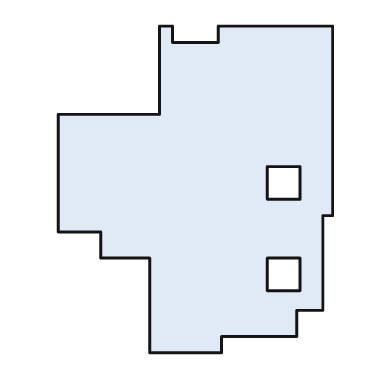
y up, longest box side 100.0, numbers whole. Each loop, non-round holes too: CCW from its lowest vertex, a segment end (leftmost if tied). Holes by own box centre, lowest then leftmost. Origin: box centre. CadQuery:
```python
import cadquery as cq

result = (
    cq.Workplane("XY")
    .moveTo(-14.0, -50.0)
    .lineTo(8.0, -50.0)
    .lineTo(8.0, -45.0)
    .lineTo(31.0, -45.0)
    .lineTo(31.0, -37.0)
    .lineTo(39.0, -37.0)
    .lineTo(39.0, -8.0)
    .lineTo(42.0, -8.0)
    .lineTo(42.0, 50.0)
    .lineTo(7.0, 50.0)
    .lineTo(7.0, 45.0)
    .lineTo(-7.0, 45.0)
    .lineTo(-7.0, 50.0)
    .lineTo(-11.0, 50.0)
    .lineTo(-11.0, 23.0)
    .lineTo(-42.0, 23.0)
    .lineTo(-42.0, -13.0)
    .lineTo(-29.0, -13.0)
    .lineTo(-29.0, -21.0)
    .lineTo(-14.0, -21.0)
    .close()
    .moveTo(22.0, -31.0)
    .lineTo(32.0, -31.0)
    .lineTo(32.0, -21.0)
    .lineTo(22.0, -21.0)
    .close()
    .moveTo(22.0, -3.0)
    .lineTo(32.0, -3.0)
    .lineTo(32.0, 7.0)
    .lineTo(22.0, 7.0)
    .close()
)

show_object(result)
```